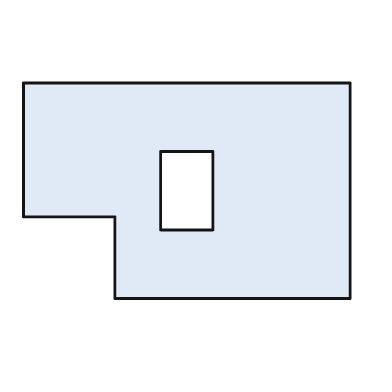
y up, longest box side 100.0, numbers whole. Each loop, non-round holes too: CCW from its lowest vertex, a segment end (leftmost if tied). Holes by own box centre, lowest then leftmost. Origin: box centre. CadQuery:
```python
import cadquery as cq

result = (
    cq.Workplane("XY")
    .moveTo(-22.0, -33.0)
    .lineTo(50.0, -33.0)
    .lineTo(50.0, 33.0)
    .lineTo(-50.0, 33.0)
    .lineTo(-50.0, -8.0)
    .lineTo(-22.0, -8.0)
    .close()
    .moveTo(-8.0, -12.0)
    .lineTo(8.0, -12.0)
    .lineTo(8.0, 12.0)
    .lineTo(-8.0, 12.0)
    .close()
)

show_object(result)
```